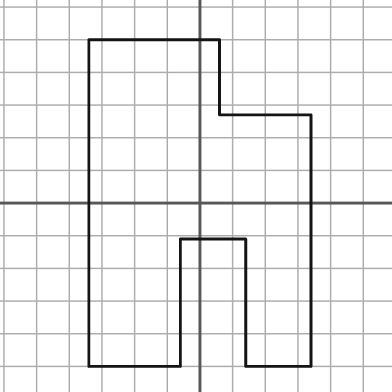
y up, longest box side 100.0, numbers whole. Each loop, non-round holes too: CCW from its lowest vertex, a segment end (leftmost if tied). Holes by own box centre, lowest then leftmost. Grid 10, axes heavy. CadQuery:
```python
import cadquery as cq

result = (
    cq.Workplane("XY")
    .moveTo(-34.0, -50.0)
    .lineTo(-6.0, -50.0)
    .lineTo(-6.0, -11.0)
    .lineTo(14.0, -11.0)
    .lineTo(14.0, -50.0)
    .lineTo(34.0, -50.0)
    .lineTo(34.0, 27.0)
    .lineTo(6.0, 27.0)
    .lineTo(6.0, 50.0)
    .lineTo(-34.0, 50.0)
    .close()
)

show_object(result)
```